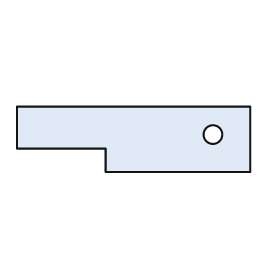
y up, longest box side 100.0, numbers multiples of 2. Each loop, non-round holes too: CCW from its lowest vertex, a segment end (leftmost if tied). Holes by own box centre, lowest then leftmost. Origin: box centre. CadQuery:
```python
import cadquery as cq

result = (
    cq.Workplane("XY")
    .moveTo(-12.0, -14.0)
    .lineTo(50.0, -14.0)
    .lineTo(50.0, 14.0)
    .lineTo(-50.0, 14.0)
    .lineTo(-50.0, -4.0)
    .lineTo(-12.0, -4.0)
    .close()
    .moveTo(34.0, 2.0)
    .circle(4.0)
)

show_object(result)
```